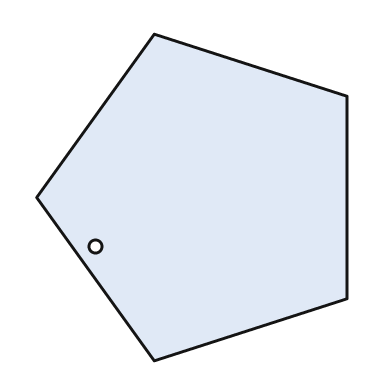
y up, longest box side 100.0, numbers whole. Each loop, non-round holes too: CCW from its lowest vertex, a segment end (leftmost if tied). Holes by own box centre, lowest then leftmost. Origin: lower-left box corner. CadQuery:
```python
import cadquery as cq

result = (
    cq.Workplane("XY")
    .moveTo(36.0, 0.0)
    .lineTo(95.0, 19.0)
    .lineTo(95.0, 81.0)
    .lineTo(36.0, 100.0)
    .lineTo(0.0, 50.0)
    .close()
    .moveTo(18.0, 35.0)
    .circle(2.0)
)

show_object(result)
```